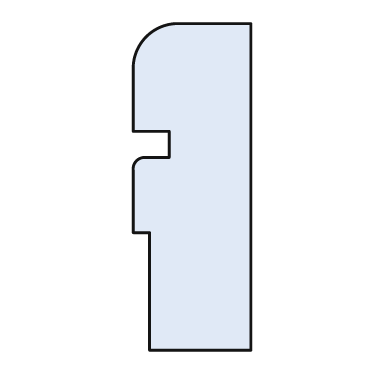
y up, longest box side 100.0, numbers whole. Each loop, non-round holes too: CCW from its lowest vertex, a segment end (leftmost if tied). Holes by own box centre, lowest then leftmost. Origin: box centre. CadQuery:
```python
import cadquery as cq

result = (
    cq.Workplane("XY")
    .moveTo(-13.0, -50.0)
    .lineTo(18.0, -50.0)
    .lineTo(18.0, 50.0)
    .lineTo(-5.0, 50.0)
    .threePointArc((-14.0, 46.0), (-18.0, 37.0))
    .lineTo(-18.0, 17.0)
    .lineTo(-7.0, 17.0)
    .lineTo(-7.0, 9.0)
    .lineTo(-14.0, 9.0)
    .threePointArc((-17.0, 8.0), (-18.0, 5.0))
    .lineTo(-18.0, -14.0)
    .lineTo(-13.0, -14.0)
    .close()
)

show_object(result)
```